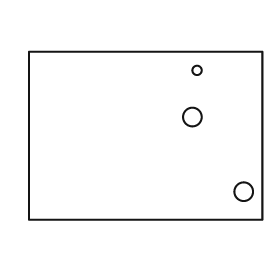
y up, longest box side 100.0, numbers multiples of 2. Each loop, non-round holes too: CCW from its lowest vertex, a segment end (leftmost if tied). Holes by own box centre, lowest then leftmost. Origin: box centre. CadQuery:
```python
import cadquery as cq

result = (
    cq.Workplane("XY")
    .moveTo(-50.0, -36.0)
    .lineTo(50.0, -36.0)
    .lineTo(50.0, 36.0)
    .lineTo(-50.0, 36.0)
    .close()
    .moveTo(42.0, -24.0)
    .circle(4.0)
    .moveTo(20.0, 8.0)
    .circle(4.0)
    .moveTo(22.0, 28.0)
    .circle(2.0)
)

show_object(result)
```